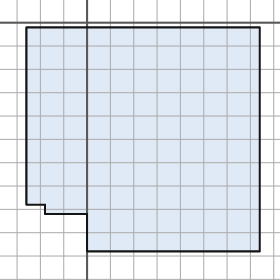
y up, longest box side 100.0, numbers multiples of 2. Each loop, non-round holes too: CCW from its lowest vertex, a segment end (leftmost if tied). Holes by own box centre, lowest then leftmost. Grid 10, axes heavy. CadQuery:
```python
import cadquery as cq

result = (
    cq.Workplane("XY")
    .moveTo(0.0, -98.0)
    .lineTo(74.0, -98.0)
    .lineTo(74.0, -2.0)
    .lineTo(-26.0, -2.0)
    .lineTo(-26.0, -78.0)
    .lineTo(-18.0, -78.0)
    .lineTo(-18.0, -82.0)
    .lineTo(0.0, -82.0)
    .close()
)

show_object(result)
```